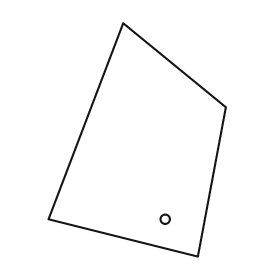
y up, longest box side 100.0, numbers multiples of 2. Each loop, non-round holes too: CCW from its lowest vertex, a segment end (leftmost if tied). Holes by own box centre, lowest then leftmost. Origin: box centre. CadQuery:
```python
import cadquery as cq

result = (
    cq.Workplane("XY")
    .moveTo(26.0, -50.0)
    .lineTo(38.0, 14.0)
    .lineTo(-6.0, 50.0)
    .lineTo(-38.0, -34.0)
    .close()
    .moveTo(12.0, -34.0)
    .circle(2.0)
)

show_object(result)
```